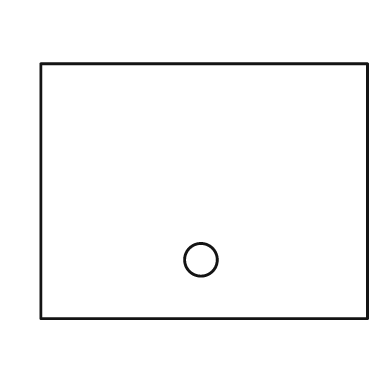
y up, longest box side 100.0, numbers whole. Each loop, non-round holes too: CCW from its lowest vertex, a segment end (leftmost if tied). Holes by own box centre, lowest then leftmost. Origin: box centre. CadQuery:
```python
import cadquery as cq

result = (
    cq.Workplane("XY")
    .moveTo(-50.0, -39.0)
    .lineTo(50.0, -39.0)
    .lineTo(50.0, 39.0)
    .lineTo(-50.0, 39.0)
    .close()
    .moveTo(-1.0, -21.0)
    .circle(5.0)
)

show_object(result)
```